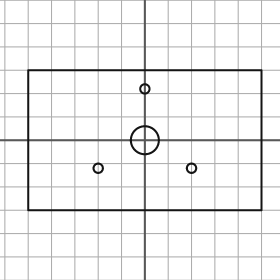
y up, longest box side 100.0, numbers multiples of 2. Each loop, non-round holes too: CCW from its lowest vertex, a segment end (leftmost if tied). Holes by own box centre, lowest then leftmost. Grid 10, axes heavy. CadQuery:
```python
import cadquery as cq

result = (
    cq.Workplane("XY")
    .moveTo(-50.0, -30.0)
    .lineTo(50.0, -30.0)
    .lineTo(50.0, 30.0)
    .lineTo(-50.0, 30.0)
    .close()
    .moveTo(-20.0, -12.0)
    .circle(2.0)
    .moveTo(20.0, -12.0)
    .circle(2.0)
    .moveTo(0.0, 0.0)
    .circle(6.0)
    .moveTo(0.0, 22.0)
    .circle(2.0)
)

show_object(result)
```